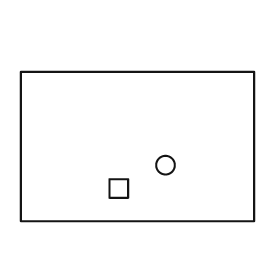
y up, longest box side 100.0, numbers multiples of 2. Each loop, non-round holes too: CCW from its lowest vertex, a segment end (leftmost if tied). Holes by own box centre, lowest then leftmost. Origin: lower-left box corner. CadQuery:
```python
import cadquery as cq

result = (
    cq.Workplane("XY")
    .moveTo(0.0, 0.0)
    .lineTo(100.0, 0.0)
    .lineTo(100.0, 64.0)
    .lineTo(0.0, 64.0)
    .close()
    .moveTo(38.0, 10.0)
    .lineTo(46.0, 10.0)
    .lineTo(46.0, 18.0)
    .lineTo(38.0, 18.0)
    .close()
    .moveTo(62.0, 24.0)
    .circle(4.0)
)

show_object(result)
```